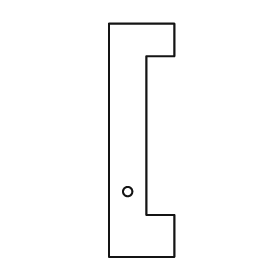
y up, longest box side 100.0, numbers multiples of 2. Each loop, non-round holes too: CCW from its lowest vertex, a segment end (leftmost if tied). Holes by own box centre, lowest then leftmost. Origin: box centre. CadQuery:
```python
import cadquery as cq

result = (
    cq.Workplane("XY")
    .moveTo(-14.0, -50.0)
    .lineTo(14.0, -50.0)
    .lineTo(14.0, -32.0)
    .lineTo(2.0, -32.0)
    .lineTo(2.0, 36.0)
    .lineTo(14.0, 36.0)
    .lineTo(14.0, 50.0)
    .lineTo(-14.0, 50.0)
    .close()
    .moveTo(-6.0, -22.0)
    .circle(2.0)
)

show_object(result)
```